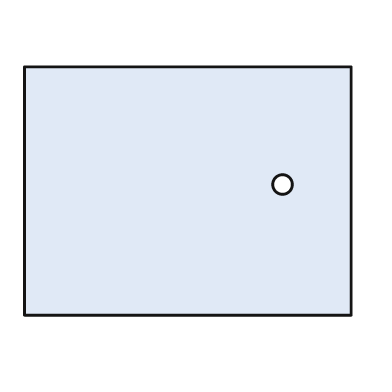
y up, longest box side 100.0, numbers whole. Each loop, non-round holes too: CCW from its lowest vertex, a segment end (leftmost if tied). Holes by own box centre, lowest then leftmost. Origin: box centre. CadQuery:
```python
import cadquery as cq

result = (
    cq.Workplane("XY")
    .moveTo(-50.0, -38.0)
    .lineTo(50.0, -38.0)
    .lineTo(50.0, 38.0)
    .lineTo(-50.0, 38.0)
    .close()
    .moveTo(29.0, 2.0)
    .circle(3.0)
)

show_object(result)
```